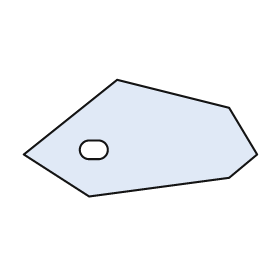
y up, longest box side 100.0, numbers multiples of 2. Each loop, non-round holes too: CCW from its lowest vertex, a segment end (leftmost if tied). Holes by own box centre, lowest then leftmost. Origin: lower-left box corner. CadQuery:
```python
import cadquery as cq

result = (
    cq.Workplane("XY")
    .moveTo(28.0, 0.0)
    .lineTo(88.0, 8.0)
    .lineTo(100.0, 18.0)
    .lineTo(88.0, 38.0)
    .lineTo(40.0, 50.0)
    .lineTo(0.0, 18.0)
    .close()
    .moveTo(28.0, 16.0)
    .lineTo(32.0, 16.0)
    .threePointArc((36.0, 20.0), (32.0, 24.0))
    .lineTo(28.0, 24.0)
    .threePointArc((24.0, 20.0), (28.0, 16.0))
    .close()
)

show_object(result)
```